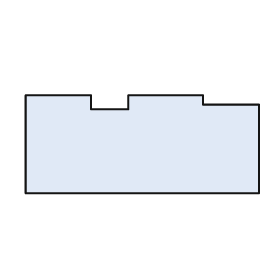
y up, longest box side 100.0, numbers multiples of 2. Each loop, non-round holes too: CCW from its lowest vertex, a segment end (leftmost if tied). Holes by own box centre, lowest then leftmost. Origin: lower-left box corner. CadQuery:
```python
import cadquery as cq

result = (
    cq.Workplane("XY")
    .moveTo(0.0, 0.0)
    .lineTo(100.0, 0.0)
    .lineTo(100.0, 38.0)
    .lineTo(76.0, 38.0)
    .lineTo(76.0, 42.0)
    .lineTo(44.0, 42.0)
    .lineTo(44.0, 36.0)
    .lineTo(28.0, 36.0)
    .lineTo(28.0, 42.0)
    .lineTo(0.0, 42.0)
    .close()
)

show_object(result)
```